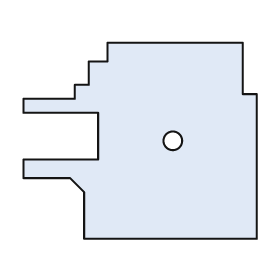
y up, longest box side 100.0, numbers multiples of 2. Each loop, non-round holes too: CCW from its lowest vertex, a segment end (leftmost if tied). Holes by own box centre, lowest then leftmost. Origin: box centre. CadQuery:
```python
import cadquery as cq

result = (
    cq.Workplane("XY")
    .moveTo(-24.0, -42.0)
    .lineTo(50.0, -42.0)
    .lineTo(50.0, 20.0)
    .lineTo(44.0, 20.0)
    .lineTo(44.0, 42.0)
    .lineTo(-14.0, 42.0)
    .lineTo(-14.0, 34.0)
    .lineTo(-22.0, 34.0)
    .lineTo(-22.0, 24.0)
    .lineTo(-28.0, 24.0)
    .lineTo(-28.0, 18.0)
    .lineTo(-50.0, 18.0)
    .lineTo(-50.0, 12.0)
    .lineTo(-18.0, 12.0)
    .lineTo(-18.0, -8.0)
    .lineTo(-50.0, -8.0)
    .lineTo(-50.0, -16.0)
    .lineTo(-30.0, -16.0)
    .lineTo(-24.0, -22.0)
    .close()
    .moveTo(14.0, 0.0)
    .circle(4.0)
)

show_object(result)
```